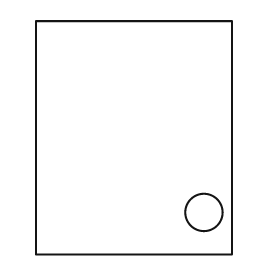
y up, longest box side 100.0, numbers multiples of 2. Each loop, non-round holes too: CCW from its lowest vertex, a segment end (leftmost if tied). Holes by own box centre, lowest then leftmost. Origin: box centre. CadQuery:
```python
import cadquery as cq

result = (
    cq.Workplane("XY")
    .moveTo(-42.0, -50.0)
    .lineTo(42.0, -50.0)
    .lineTo(42.0, 50.0)
    .lineTo(-42.0, 50.0)
    .close()
    .moveTo(30.0, -32.0)
    .circle(8.0)
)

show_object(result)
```